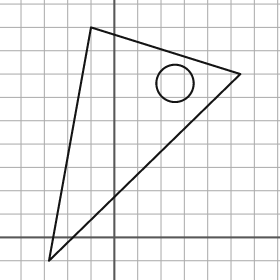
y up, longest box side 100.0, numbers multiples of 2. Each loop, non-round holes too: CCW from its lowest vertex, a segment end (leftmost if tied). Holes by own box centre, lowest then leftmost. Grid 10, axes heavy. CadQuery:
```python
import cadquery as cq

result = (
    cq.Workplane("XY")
    .moveTo(-28.0, -10.0)
    .lineTo(54.0, 70.0)
    .lineTo(-10.0, 90.0)
    .close()
    .moveTo(26.0, 66.0)
    .circle(8.0)
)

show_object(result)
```